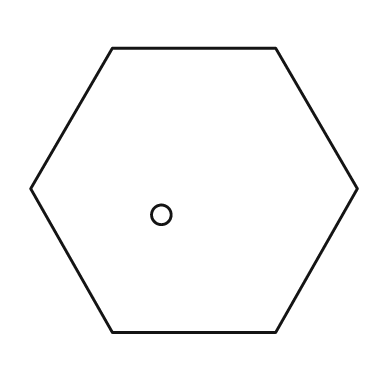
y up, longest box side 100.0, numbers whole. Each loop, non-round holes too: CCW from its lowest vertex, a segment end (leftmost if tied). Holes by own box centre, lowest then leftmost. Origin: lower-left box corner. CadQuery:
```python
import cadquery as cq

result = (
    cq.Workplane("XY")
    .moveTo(25.0, 0.0)
    .lineTo(75.0, 0.0)
    .lineTo(100.0, 44.0)
    .lineTo(75.0, 87.0)
    .lineTo(25.0, 87.0)
    .lineTo(0.0, 44.0)
    .close()
    .moveTo(40.0, 36.0)
    .circle(3.0)
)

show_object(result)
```